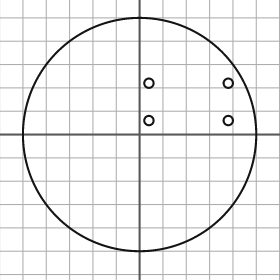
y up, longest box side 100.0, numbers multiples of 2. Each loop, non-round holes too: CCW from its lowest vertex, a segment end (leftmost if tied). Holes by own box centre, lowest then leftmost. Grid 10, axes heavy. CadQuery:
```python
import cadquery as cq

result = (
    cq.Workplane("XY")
    .moveTo(0.0, 0.0)
    .circle(50.0)
    .moveTo(4.0, 6.0)
    .circle(2.0)
    .moveTo(38.0, 6.0)
    .circle(2.0)
    .moveTo(4.0, 22.0)
    .circle(2.0)
    .moveTo(38.0, 22.0)
    .circle(2.0)
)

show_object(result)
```